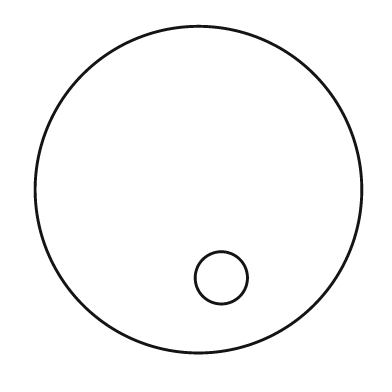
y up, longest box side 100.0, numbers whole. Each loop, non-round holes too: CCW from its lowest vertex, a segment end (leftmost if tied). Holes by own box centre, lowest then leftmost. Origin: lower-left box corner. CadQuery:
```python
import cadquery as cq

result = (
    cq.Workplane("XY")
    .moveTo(50.0, 50.0)
    .circle(50.0)
    .moveTo(57.0, 23.0)
    .circle(8.0)
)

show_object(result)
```